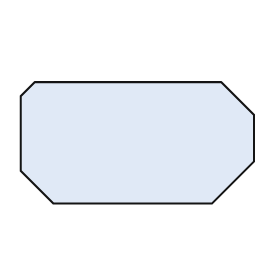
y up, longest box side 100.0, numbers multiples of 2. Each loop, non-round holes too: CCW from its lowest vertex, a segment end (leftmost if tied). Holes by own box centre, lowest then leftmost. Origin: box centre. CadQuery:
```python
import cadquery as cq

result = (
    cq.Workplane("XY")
    .moveTo(-36.0, -26.0)
    .lineTo(32.0, -26.0)
    .lineTo(50.0, -8.0)
    .lineTo(50.0, 12.0)
    .lineTo(36.0, 26.0)
    .lineTo(-44.0, 26.0)
    .lineTo(-50.0, 20.0)
    .lineTo(-50.0, -12.0)
    .close()
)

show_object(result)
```